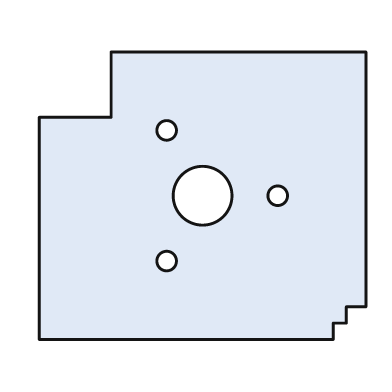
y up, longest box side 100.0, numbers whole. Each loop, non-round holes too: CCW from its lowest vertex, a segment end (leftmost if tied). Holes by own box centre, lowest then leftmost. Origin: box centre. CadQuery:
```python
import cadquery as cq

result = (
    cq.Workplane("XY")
    .moveTo(-50.0, -44.0)
    .lineTo(40.0, -44.0)
    .lineTo(40.0, -39.0)
    .lineTo(44.0, -39.0)
    .lineTo(44.0, -34.0)
    .lineTo(50.0, -34.0)
    .lineTo(50.0, 44.0)
    .lineTo(-28.0, 44.0)
    .lineTo(-28.0, 24.0)
    .lineTo(-50.0, 24.0)
    .close()
    .moveTo(-11.0, -20.0)
    .circle(3.0)
    .moveTo(0.0, 0.0)
    .circle(9.0)
    .moveTo(23.0, 0.0)
    .circle(3.0)
    .moveTo(-11.0, 20.0)
    .circle(3.0)
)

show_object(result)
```